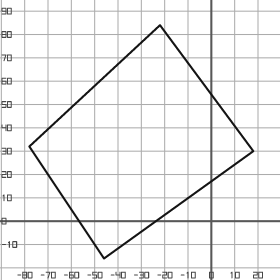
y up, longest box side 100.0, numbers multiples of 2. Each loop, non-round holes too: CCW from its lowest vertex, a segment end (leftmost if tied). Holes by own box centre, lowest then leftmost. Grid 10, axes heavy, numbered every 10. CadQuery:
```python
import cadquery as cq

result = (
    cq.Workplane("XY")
    .moveTo(-46.0, -16.0)
    .lineTo(18.0, 30.0)
    .lineTo(-22.0, 84.0)
    .lineTo(-78.0, 32.0)
    .close()
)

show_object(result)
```